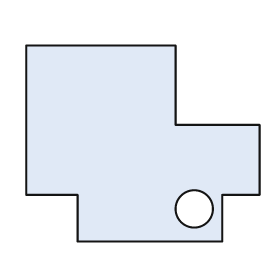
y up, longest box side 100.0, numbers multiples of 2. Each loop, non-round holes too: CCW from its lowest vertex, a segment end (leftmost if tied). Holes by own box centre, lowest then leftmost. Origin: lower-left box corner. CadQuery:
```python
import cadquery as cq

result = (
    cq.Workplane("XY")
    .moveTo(22.0, 0.0)
    .lineTo(84.0, 0.0)
    .lineTo(84.0, 20.0)
    .lineTo(100.0, 20.0)
    .lineTo(100.0, 50.0)
    .lineTo(64.0, 50.0)
    .lineTo(64.0, 84.0)
    .lineTo(0.0, 84.0)
    .lineTo(0.0, 20.0)
    .lineTo(22.0, 20.0)
    .close()
    .moveTo(72.0, 14.0)
    .circle(8.0)
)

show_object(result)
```